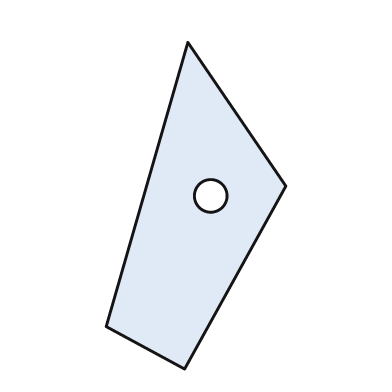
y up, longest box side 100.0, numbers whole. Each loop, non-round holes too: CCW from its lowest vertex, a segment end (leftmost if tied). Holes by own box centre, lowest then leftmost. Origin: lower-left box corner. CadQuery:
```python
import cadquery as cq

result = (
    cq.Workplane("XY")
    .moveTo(24.0, 0.0)
    .lineTo(55.0, 56.0)
    .lineTo(25.0, 100.0)
    .lineTo(0.0, 13.0)
    .close()
    .moveTo(32.0, 53.0)
    .circle(5.0)
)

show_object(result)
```